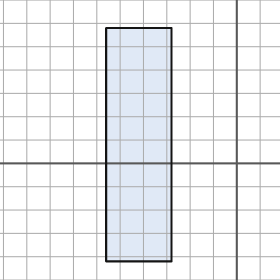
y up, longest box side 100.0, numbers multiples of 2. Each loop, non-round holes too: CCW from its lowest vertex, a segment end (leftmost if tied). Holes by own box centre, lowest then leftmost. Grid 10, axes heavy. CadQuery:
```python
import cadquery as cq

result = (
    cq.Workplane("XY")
    .moveTo(-56.0, -42.0)
    .lineTo(-28.0, -42.0)
    .lineTo(-28.0, 58.0)
    .lineTo(-56.0, 58.0)
    .close()
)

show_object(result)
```